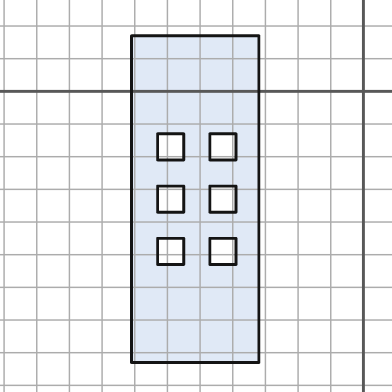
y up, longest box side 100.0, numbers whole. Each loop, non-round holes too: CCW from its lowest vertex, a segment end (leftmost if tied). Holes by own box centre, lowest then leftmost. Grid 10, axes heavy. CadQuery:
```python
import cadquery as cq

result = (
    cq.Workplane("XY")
    .moveTo(-71.0, -83.0)
    .lineTo(-32.0, -83.0)
    .lineTo(-32.0, 17.0)
    .lineTo(-71.0, 17.0)
    .close()
    .moveTo(-63.0, -53.0)
    .lineTo(-55.0, -53.0)
    .lineTo(-55.0, -45.0)
    .lineTo(-63.0, -45.0)
    .close()
    .moveTo(-47.0, -53.0)
    .lineTo(-39.0, -53.0)
    .lineTo(-39.0, -45.0)
    .lineTo(-47.0, -45.0)
    .close()
    .moveTo(-63.0, -37.0)
    .lineTo(-55.0, -37.0)
    .lineTo(-55.0, -29.0)
    .lineTo(-63.0, -29.0)
    .close()
    .moveTo(-47.0, -37.0)
    .lineTo(-39.0, -37.0)
    .lineTo(-39.0, -29.0)
    .lineTo(-47.0, -29.0)
    .close()
    .moveTo(-63.0, -21.0)
    .lineTo(-55.0, -21.0)
    .lineTo(-55.0, -13.0)
    .lineTo(-63.0, -13.0)
    .close()
    .moveTo(-47.0, -21.0)
    .lineTo(-39.0, -21.0)
    .lineTo(-39.0, -13.0)
    .lineTo(-47.0, -13.0)
    .close()
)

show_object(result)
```